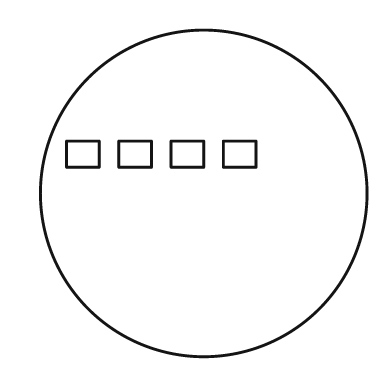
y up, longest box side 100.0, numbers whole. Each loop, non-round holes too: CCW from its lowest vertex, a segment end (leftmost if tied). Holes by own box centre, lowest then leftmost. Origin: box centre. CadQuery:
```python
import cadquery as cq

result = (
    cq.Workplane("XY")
    .moveTo(0.0, 0.0)
    .circle(50.0)
    .moveTo(-42.0, 8.0)
    .lineTo(-32.0, 8.0)
    .lineTo(-32.0, 16.0)
    .lineTo(-42.0, 16.0)
    .close()
    .moveTo(-26.0, 8.0)
    .lineTo(-16.0, 8.0)
    .lineTo(-16.0, 16.0)
    .lineTo(-26.0, 16.0)
    .close()
    .moveTo(-10.0, 8.0)
    .lineTo(0.0, 8.0)
    .lineTo(0.0, 16.0)
    .lineTo(-10.0, 16.0)
    .close()
    .moveTo(6.0, 8.0)
    .lineTo(16.0, 8.0)
    .lineTo(16.0, 16.0)
    .lineTo(6.0, 16.0)
    .close()
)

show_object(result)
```